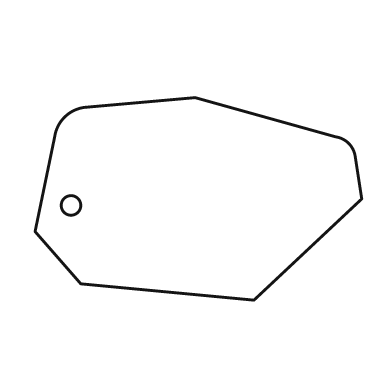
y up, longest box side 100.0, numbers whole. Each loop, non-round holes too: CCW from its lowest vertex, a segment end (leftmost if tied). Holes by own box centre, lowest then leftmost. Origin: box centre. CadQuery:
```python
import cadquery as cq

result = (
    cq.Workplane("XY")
    .moveTo(17.0, -31.0)
    .lineTo(50.0, 0.0)
    .lineTo(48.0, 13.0)
    .threePointArc((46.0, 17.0), (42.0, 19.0))
    .lineTo(-1.0, 31.0)
    .lineTo(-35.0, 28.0)
    .threePointArc((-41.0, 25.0), (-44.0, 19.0))
    .lineTo(-50.0, -10.0)
    .lineTo(-36.0, -26.0)
    .close()
    .moveTo(-39.0, -2.0)
    .circle(3.0)
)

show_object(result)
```